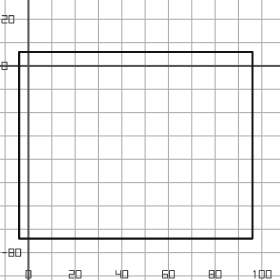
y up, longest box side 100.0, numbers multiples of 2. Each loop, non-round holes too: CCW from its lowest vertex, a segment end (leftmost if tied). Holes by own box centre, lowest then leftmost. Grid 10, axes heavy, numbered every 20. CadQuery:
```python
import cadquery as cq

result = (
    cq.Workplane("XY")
    .moveTo(-4.0, -74.0)
    .lineTo(96.0, -74.0)
    .lineTo(96.0, 6.0)
    .lineTo(-4.0, 6.0)
    .close()
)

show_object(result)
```